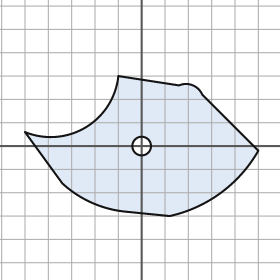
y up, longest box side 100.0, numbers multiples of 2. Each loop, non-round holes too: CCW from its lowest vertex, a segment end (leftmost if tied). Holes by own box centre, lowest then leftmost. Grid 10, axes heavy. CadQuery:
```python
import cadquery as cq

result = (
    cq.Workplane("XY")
    .moveTo(12.0, -30.0)
    .threePointArc((34.0, -20.0), (50.0, -2.0))
    .lineTo(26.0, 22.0)
    .threePointArc((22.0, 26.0), (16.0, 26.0))
    .lineTo(-10.0, 30.0)
    .threePointArc((-24.0, 8.0), (-50.0, 6.0))
    .lineTo(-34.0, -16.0)
    .threePointArc((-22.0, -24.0), (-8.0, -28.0))
    .close()
    .moveTo(0.0, 0.0)
    .circle(4.0)
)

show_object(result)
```